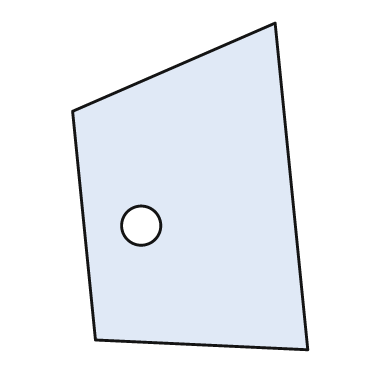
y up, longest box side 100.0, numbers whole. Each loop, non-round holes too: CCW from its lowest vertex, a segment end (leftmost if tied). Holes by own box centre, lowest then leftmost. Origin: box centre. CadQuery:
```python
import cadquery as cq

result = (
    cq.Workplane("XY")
    .moveTo(36.0, -50.0)
    .lineTo(26.0, 50.0)
    .lineTo(-36.0, 23.0)
    .lineTo(-29.0, -47.0)
    .close()
    .moveTo(-15.0, -12.0)
    .circle(6.0)
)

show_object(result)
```